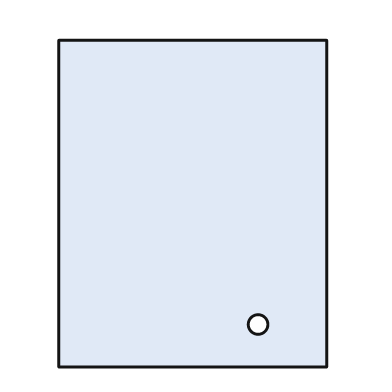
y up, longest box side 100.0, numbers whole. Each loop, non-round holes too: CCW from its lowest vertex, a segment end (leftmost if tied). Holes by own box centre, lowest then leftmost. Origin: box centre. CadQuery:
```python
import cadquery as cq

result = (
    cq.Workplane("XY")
    .moveTo(-41.0, -50.0)
    .lineTo(41.0, -50.0)
    .lineTo(41.0, 50.0)
    .lineTo(-41.0, 50.0)
    .close()
    .moveTo(20.0, -37.0)
    .circle(3.0)
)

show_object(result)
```